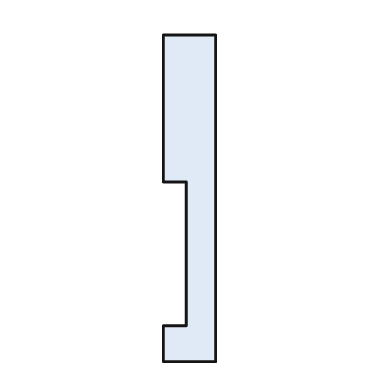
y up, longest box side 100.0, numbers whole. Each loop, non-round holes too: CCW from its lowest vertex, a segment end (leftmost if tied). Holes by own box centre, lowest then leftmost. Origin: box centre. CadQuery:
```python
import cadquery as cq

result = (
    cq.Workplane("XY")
    .moveTo(-8.0, -50.0)
    .lineTo(8.0, -50.0)
    .lineTo(8.0, 50.0)
    .lineTo(-8.0, 50.0)
    .lineTo(-8.0, 5.0)
    .lineTo(-1.0, 5.0)
    .lineTo(-1.0, -39.0)
    .lineTo(-8.0, -39.0)
    .close()
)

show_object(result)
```